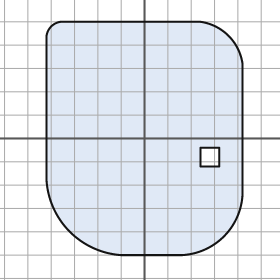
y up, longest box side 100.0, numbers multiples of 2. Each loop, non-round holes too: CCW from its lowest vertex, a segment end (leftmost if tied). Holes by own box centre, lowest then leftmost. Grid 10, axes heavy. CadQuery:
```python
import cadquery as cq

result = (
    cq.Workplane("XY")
    .moveTo(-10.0, -50.0)
    .lineTo(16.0, -50.0)
    .threePointArc((34.0, -42.0), (42.0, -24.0))
    .lineTo(42.0, 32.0)
    .threePointArc((36.0, 44.0), (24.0, 50.0))
    .lineTo(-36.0, 50.0)
    .threePointArc((-40.0, 48.0), (-42.0, 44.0))
    .lineTo(-42.0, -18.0)
    .threePointArc((-32.0, -40.0), (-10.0, -50.0))
    .close()
    .moveTo(24.0, -12.0)
    .lineTo(32.0, -12.0)
    .lineTo(32.0, -4.0)
    .lineTo(24.0, -4.0)
    .close()
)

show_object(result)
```